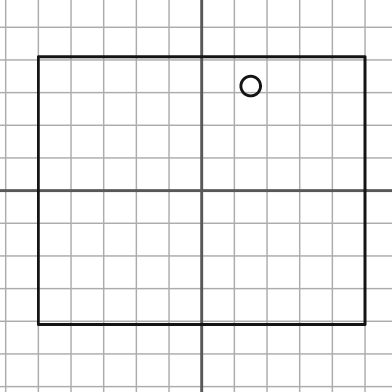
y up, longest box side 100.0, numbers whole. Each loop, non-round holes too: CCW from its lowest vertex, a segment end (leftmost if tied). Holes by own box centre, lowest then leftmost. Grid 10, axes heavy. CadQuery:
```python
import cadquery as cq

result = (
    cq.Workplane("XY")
    .moveTo(-50.0, -41.0)
    .lineTo(50.0, -41.0)
    .lineTo(50.0, 41.0)
    .lineTo(-50.0, 41.0)
    .close()
    .moveTo(15.0, 32.0)
    .circle(3.0)
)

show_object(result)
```